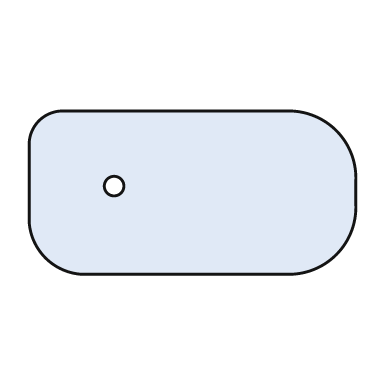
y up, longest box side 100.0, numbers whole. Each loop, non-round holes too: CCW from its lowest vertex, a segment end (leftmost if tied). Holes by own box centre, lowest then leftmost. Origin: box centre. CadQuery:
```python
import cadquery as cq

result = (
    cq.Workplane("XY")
    .moveTo(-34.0, -25.0)
    .lineTo(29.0, -25.0)
    .threePointArc((44.0, -19.0), (50.0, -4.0))
    .lineTo(50.0, 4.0)
    .threePointArc((44.0, 19.0), (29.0, 25.0))
    .lineTo(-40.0, 25.0)
    .threePointArc((-47.0, 22.0), (-50.0, 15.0))
    .lineTo(-50.0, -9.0)
    .threePointArc((-45.0, -20.0), (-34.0, -25.0))
    .close()
    .moveTo(-24.0, 2.0)
    .circle(3.0)
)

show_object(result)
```